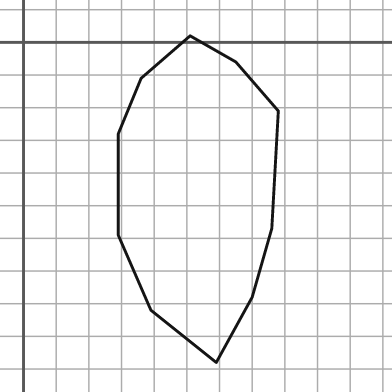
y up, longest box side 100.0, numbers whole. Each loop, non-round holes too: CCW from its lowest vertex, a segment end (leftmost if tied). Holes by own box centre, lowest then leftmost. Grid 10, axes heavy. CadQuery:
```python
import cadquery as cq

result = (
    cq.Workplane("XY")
    .moveTo(59.0, -98.0)
    .lineTo(70.0, -78.0)
    .lineTo(76.0, -57.0)
    .lineTo(78.0, -21.0)
    .lineTo(65.0, -6.0)
    .lineTo(51.0, 2.0)
    .lineTo(36.0, -11.0)
    .lineTo(29.0, -28.0)
    .lineTo(29.0, -59.0)
    .lineTo(39.0, -82.0)
    .close()
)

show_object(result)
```